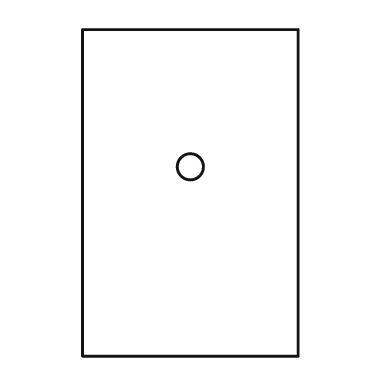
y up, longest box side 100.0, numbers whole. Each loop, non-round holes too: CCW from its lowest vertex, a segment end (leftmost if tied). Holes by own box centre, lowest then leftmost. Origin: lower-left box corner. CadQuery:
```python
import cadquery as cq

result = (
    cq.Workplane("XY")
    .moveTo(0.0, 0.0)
    .lineTo(66.0, 0.0)
    .lineTo(66.0, 100.0)
    .lineTo(0.0, 100.0)
    .close()
    .moveTo(33.0, 58.0)
    .circle(4.0)
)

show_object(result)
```